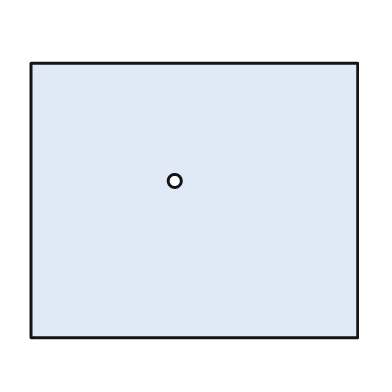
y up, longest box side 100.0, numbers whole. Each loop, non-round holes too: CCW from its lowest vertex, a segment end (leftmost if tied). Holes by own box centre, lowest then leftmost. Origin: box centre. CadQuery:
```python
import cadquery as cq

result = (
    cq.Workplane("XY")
    .moveTo(-50.0, -42.0)
    .lineTo(50.0, -42.0)
    .lineTo(50.0, 42.0)
    .lineTo(-50.0, 42.0)
    .close()
    .moveTo(-6.0, 6.0)
    .circle(2.0)
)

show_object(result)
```